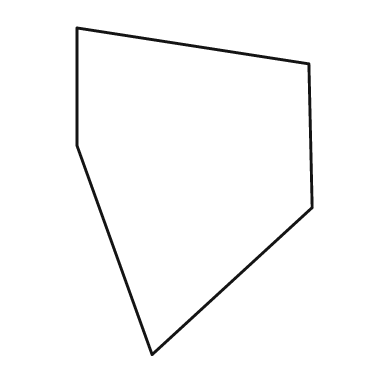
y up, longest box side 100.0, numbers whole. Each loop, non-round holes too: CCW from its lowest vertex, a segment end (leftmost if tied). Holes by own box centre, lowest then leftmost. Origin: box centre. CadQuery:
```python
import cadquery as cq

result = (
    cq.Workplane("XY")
    .moveTo(-13.0, -50.0)
    .lineTo(36.0, -5.0)
    .lineTo(35.0, 39.0)
    .lineTo(-36.0, 50.0)
    .lineTo(-36.0, 14.0)
    .close()
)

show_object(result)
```